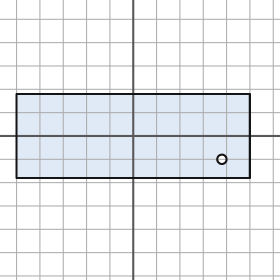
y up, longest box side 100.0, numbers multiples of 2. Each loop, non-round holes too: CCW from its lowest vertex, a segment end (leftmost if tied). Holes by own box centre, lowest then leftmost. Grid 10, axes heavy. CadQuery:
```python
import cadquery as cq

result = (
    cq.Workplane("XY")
    .moveTo(-50.0, -18.0)
    .lineTo(50.0, -18.0)
    .lineTo(50.0, 18.0)
    .lineTo(-50.0, 18.0)
    .close()
    .moveTo(38.0, -10.0)
    .circle(2.0)
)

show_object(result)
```